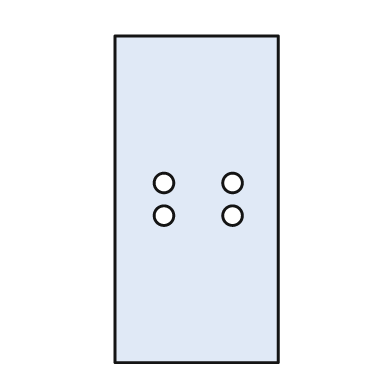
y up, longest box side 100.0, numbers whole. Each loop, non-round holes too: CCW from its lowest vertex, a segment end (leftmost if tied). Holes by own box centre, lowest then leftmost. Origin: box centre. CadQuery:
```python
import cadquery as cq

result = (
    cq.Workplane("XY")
    .moveTo(-25.0, -50.0)
    .lineTo(25.0, -50.0)
    .lineTo(25.0, 50.0)
    .lineTo(-25.0, 50.0)
    .close()
    .moveTo(-10.0, -5.0)
    .circle(3.0)
    .moveTo(11.0, -5.0)
    .circle(3.0)
    .moveTo(-10.0, 5.0)
    .circle(3.0)
    .moveTo(11.0, 5.0)
    .circle(3.0)
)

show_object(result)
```